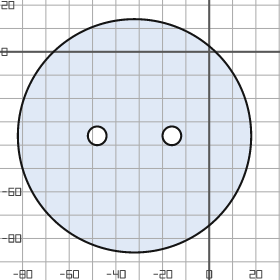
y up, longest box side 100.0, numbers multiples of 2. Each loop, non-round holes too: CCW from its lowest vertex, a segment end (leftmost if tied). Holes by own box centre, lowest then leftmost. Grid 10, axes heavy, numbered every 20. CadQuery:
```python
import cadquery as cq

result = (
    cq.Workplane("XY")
    .moveTo(-32.0, -36.0)
    .circle(50.0)
    .moveTo(-48.0, -36.0)
    .circle(4.0)
    .moveTo(-16.0, -36.0)
    .circle(4.0)
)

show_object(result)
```